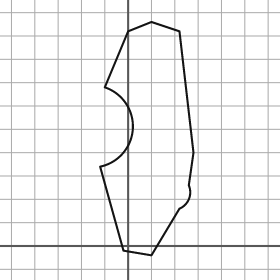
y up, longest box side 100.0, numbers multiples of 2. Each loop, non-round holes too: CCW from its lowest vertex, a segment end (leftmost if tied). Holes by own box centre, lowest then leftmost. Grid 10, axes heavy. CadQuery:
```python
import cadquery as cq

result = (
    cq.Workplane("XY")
    .moveTo(10.0, -4.0)
    .lineTo(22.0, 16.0)
    .threePointArc((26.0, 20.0), (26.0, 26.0))
    .lineTo(28.0, 40.0)
    .lineTo(22.0, 92.0)
    .lineTo(10.0, 96.0)
    .lineTo(0.0, 92.0)
    .lineTo(-10.0, 68.0)
    .threePointArc((2.0, 50.0), (-12.0, 34.0))
    .lineTo(-2.0, -2.0)
    .close()
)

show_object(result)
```